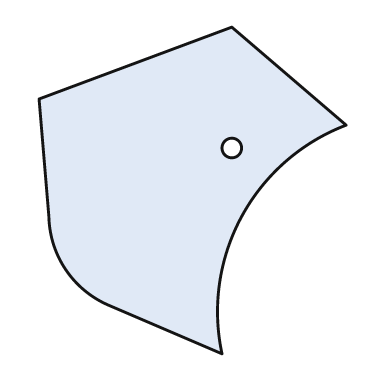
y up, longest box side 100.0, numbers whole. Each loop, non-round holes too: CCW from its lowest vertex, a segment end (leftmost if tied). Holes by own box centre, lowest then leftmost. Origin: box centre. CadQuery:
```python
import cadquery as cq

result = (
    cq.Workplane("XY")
    .moveTo(9.0, -50.0)
    .threePointArc((15.0, -8.0), (47.0, 20.0))
    .lineTo(12.0, 50.0)
    .lineTo(-47.0, 28.0)
    .lineTo(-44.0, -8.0)
    .threePointArc((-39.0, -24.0), (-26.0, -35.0))
    .close()
    .moveTo(12.0, 13.0)
    .circle(3.0)
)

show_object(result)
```